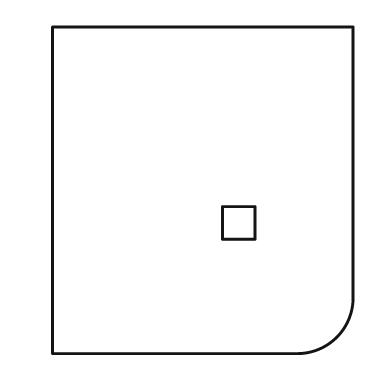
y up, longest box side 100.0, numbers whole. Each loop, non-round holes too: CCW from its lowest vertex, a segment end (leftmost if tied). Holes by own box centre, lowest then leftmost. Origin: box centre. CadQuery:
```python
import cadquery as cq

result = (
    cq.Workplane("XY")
    .moveTo(-46.0, -50.0)
    .lineTo(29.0, -50.0)
    .threePointArc((41.0, -45.0), (46.0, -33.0))
    .lineTo(46.0, 50.0)
    .lineTo(-46.0, 50.0)
    .close()
    .moveTo(6.0, -15.0)
    .lineTo(16.0, -15.0)
    .lineTo(16.0, -5.0)
    .lineTo(6.0, -5.0)
    .close()
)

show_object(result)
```